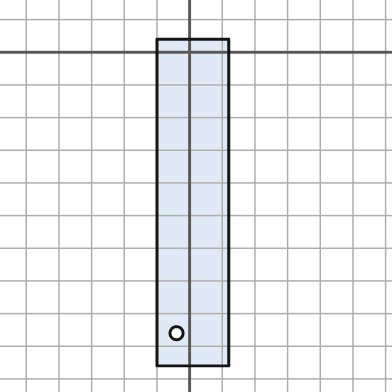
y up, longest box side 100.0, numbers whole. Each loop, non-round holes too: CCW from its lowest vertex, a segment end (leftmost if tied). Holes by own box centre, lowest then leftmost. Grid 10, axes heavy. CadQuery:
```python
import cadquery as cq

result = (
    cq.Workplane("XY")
    .moveTo(-10.0, -96.0)
    .lineTo(12.0, -96.0)
    .lineTo(12.0, 4.0)
    .lineTo(-10.0, 4.0)
    .close()
    .moveTo(-4.0, -86.0)
    .circle(2.0)
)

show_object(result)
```